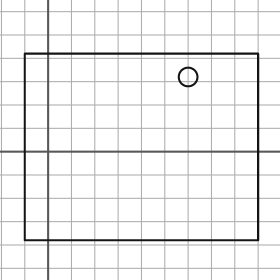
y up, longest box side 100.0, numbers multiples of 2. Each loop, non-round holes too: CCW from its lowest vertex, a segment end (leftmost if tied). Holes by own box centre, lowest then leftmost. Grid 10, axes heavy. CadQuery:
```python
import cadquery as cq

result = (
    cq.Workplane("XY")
    .moveTo(-10.0, -38.0)
    .lineTo(90.0, -38.0)
    .lineTo(90.0, 42.0)
    .lineTo(-10.0, 42.0)
    .close()
    .moveTo(60.0, 32.0)
    .circle(4.0)
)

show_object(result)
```